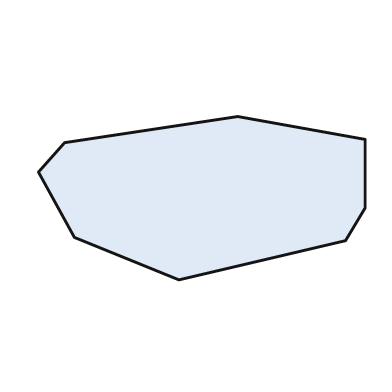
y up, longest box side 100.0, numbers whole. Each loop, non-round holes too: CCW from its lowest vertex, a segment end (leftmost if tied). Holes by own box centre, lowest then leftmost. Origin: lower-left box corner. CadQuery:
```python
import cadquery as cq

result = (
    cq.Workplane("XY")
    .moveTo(43.0, 0.0)
    .lineTo(94.0, 12.0)
    .lineTo(100.0, 22.0)
    .lineTo(100.0, 43.0)
    .lineTo(61.0, 50.0)
    .lineTo(8.0, 42.0)
    .lineTo(0.0, 33.0)
    .lineTo(11.0, 13.0)
    .close()
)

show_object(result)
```